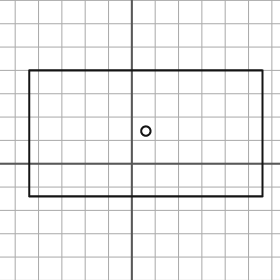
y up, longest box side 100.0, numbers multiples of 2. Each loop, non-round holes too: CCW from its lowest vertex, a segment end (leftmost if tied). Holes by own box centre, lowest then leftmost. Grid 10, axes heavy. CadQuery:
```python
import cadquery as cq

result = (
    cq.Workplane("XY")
    .moveTo(-44.0, -14.0)
    .lineTo(56.0, -14.0)
    .lineTo(56.0, 40.0)
    .lineTo(-44.0, 40.0)
    .close()
    .moveTo(6.0, 14.0)
    .circle(2.0)
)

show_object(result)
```